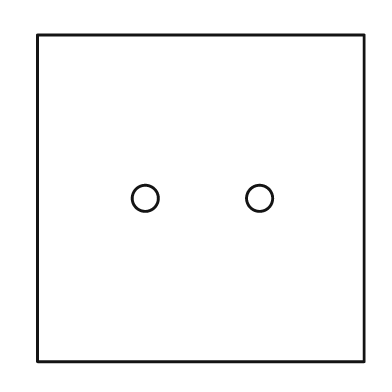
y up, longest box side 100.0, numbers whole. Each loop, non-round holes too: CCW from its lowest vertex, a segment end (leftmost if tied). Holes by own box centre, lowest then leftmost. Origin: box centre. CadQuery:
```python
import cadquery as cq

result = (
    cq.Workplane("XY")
    .moveTo(-50.0, -50.0)
    .lineTo(50.0, -50.0)
    .lineTo(50.0, 50.0)
    .lineTo(-50.0, 50.0)
    .close()
    .moveTo(-17.0, 0.0)
    .circle(4.0)
    .moveTo(18.0, 0.0)
    .circle(4.0)
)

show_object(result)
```